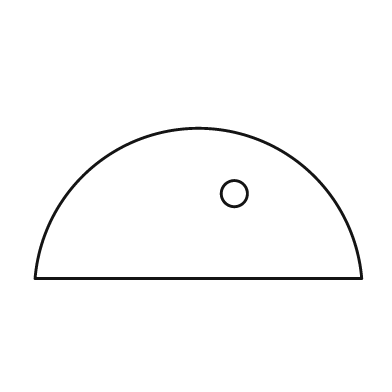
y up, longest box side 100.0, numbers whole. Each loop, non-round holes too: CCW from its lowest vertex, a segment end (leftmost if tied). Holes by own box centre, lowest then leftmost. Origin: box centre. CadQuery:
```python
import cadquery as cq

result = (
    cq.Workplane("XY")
    .moveTo(-50.0, -23.0)
    .lineTo(50.0, -23.0)
    .threePointArc((0.0, 23.0), (-50.0, -23.0))
    .close()
    .moveTo(11.0, 3.0)
    .circle(4.0)
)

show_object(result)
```